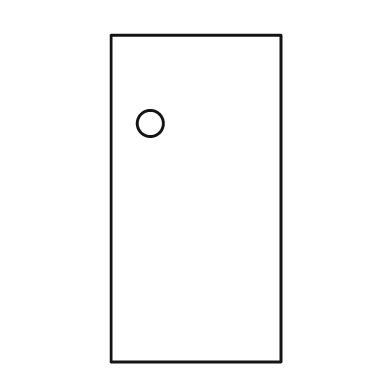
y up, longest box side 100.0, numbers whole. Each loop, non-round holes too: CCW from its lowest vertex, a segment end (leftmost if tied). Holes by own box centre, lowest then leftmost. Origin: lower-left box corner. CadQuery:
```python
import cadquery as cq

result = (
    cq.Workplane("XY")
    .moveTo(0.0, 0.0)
    .lineTo(52.0, 0.0)
    .lineTo(52.0, 100.0)
    .lineTo(0.0, 100.0)
    .close()
    .moveTo(12.0, 73.0)
    .circle(4.0)
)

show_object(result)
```